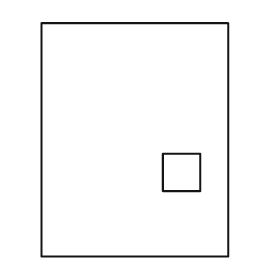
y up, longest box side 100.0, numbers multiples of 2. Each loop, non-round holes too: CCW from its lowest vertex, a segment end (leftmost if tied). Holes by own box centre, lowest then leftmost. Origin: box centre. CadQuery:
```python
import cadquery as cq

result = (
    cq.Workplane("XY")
    .moveTo(-40.0, -50.0)
    .lineTo(40.0, -50.0)
    .lineTo(40.0, 50.0)
    .lineTo(-40.0, 50.0)
    .close()
    .moveTo(12.0, -22.0)
    .lineTo(28.0, -22.0)
    .lineTo(28.0, -6.0)
    .lineTo(12.0, -6.0)
    .close()
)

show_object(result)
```